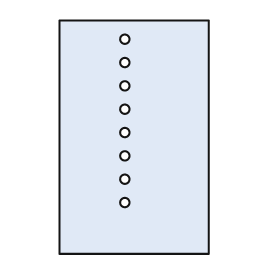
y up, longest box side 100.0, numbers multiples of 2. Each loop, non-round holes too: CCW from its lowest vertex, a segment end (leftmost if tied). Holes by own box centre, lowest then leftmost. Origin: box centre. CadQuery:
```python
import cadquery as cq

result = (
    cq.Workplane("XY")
    .moveTo(-32.0, -50.0)
    .lineTo(32.0, -50.0)
    .lineTo(32.0, 50.0)
    .lineTo(-32.0, 50.0)
    .close()
    .moveTo(-4.0, -28.0)
    .circle(2.0)
    .moveTo(-4.0, -18.0)
    .circle(2.0)
    .moveTo(-4.0, -8.0)
    .circle(2.0)
    .moveTo(-4.0, 2.0)
    .circle(2.0)
    .moveTo(-4.0, 12.0)
    .circle(2.0)
    .moveTo(-4.0, 22.0)
    .circle(2.0)
    .moveTo(-4.0, 32.0)
    .circle(2.0)
    .moveTo(-4.0, 42.0)
    .circle(2.0)
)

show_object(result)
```